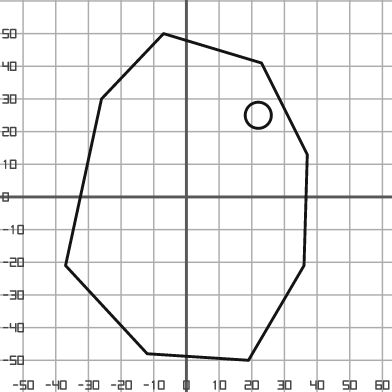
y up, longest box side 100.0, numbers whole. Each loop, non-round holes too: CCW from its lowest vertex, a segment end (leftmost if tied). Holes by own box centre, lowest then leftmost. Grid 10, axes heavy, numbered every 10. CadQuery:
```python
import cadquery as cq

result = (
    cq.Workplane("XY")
    .moveTo(19.0, -50.0)
    .lineTo(36.0, -21.0)
    .lineTo(37.0, 13.0)
    .lineTo(23.0, 41.0)
    .lineTo(-7.0, 50.0)
    .lineTo(-26.0, 30.0)
    .lineTo(-37.0, -21.0)
    .lineTo(-12.0, -48.0)
    .close()
    .moveTo(22.0, 25.0)
    .circle(4.0)
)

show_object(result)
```